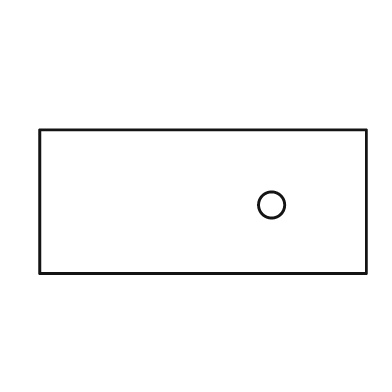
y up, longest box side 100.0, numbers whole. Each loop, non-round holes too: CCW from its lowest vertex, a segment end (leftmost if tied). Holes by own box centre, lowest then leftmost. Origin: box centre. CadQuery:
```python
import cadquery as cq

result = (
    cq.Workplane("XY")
    .moveTo(-50.0, -22.0)
    .lineTo(50.0, -22.0)
    .lineTo(50.0, 22.0)
    .lineTo(-50.0, 22.0)
    .close()
    .moveTo(21.0, -1.0)
    .circle(4.0)
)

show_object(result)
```